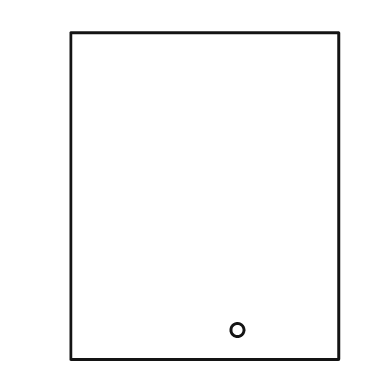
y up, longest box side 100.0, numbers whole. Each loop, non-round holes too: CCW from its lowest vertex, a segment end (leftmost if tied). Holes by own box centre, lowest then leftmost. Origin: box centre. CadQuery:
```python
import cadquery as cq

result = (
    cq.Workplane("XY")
    .moveTo(-41.0, -50.0)
    .lineTo(41.0, -50.0)
    .lineTo(41.0, 50.0)
    .lineTo(-41.0, 50.0)
    .close()
    .moveTo(10.0, -41.0)
    .circle(2.0)
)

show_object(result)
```